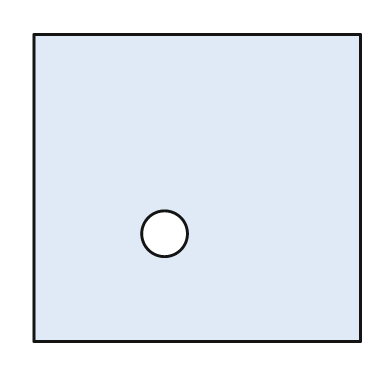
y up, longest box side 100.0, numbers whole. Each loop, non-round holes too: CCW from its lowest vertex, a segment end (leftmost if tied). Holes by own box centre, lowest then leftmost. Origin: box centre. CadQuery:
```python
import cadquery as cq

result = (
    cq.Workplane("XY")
    .moveTo(-50.0, -47.0)
    .lineTo(50.0, -47.0)
    .lineTo(50.0, 47.0)
    .lineTo(-50.0, 47.0)
    .close()
    .moveTo(-10.0, -14.0)
    .circle(7.0)
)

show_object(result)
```